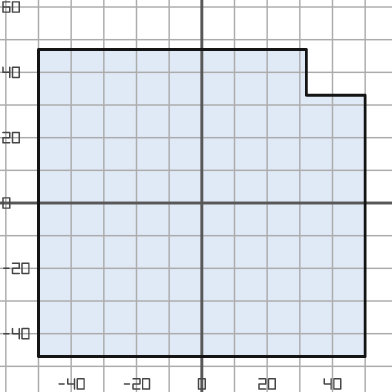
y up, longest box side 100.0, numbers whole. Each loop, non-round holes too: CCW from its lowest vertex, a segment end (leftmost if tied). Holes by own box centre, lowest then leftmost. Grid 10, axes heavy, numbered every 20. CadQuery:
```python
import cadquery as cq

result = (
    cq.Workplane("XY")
    .moveTo(-50.0, -47.0)
    .lineTo(50.0, -47.0)
    .lineTo(50.0, 33.0)
    .lineTo(32.0, 33.0)
    .lineTo(32.0, 47.0)
    .lineTo(-50.0, 47.0)
    .close()
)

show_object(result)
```